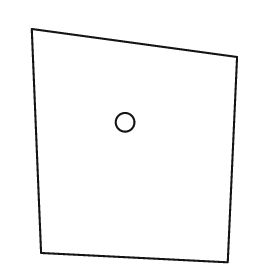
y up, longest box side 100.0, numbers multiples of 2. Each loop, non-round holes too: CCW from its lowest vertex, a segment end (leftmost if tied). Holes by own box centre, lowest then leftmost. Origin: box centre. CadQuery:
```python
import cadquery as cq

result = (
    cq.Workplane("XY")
    .moveTo(40.0, -50.0)
    .lineTo(44.0, 38.0)
    .lineTo(-44.0, 50.0)
    .lineTo(-40.0, -46.0)
    .close()
    .moveTo(-4.0, 10.0)
    .circle(4.0)
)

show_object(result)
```